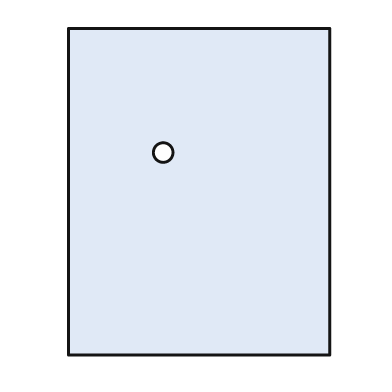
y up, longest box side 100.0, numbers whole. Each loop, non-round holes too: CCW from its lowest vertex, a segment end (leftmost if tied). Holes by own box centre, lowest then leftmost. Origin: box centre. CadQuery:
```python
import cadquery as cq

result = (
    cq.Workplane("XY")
    .moveTo(-40.0, -50.0)
    .lineTo(40.0, -50.0)
    .lineTo(40.0, 50.0)
    .lineTo(-40.0, 50.0)
    .close()
    .moveTo(-11.0, 12.0)
    .circle(3.0)
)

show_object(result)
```